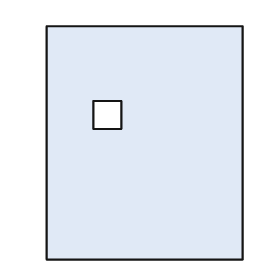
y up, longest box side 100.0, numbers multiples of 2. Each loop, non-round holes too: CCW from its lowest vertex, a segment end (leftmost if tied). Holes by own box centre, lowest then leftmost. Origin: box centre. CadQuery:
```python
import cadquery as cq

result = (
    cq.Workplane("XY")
    .moveTo(-42.0, -50.0)
    .lineTo(42.0, -50.0)
    .lineTo(42.0, 50.0)
    .lineTo(-42.0, 50.0)
    .close()
    .moveTo(-22.0, 6.0)
    .lineTo(-10.0, 6.0)
    .lineTo(-10.0, 18.0)
    .lineTo(-22.0, 18.0)
    .close()
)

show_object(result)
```